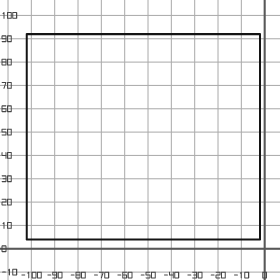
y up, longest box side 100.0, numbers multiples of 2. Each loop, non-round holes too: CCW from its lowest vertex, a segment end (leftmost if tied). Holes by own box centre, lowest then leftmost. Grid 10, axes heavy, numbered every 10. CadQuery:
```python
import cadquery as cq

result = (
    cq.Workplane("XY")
    .moveTo(-102.0, 4.0)
    .lineTo(-2.0, 4.0)
    .lineTo(-2.0, 92.0)
    .lineTo(-102.0, 92.0)
    .close()
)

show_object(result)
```